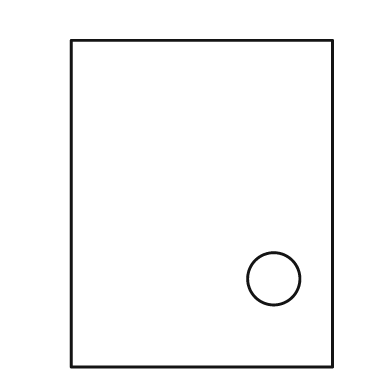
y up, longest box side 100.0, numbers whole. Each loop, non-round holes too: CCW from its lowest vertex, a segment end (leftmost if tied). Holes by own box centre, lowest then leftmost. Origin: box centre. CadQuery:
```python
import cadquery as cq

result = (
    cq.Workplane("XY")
    .moveTo(-40.0, -50.0)
    .lineTo(40.0, -50.0)
    .lineTo(40.0, 50.0)
    .lineTo(-40.0, 50.0)
    .close()
    .moveTo(22.0, -23.0)
    .circle(8.0)
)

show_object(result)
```